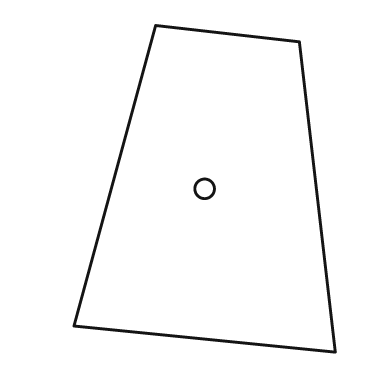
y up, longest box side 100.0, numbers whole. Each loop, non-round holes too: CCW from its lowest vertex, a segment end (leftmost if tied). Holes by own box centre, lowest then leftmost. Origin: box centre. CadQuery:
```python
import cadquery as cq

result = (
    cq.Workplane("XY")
    .moveTo(40.0, -50.0)
    .lineTo(29.0, 45.0)
    .lineTo(-15.0, 50.0)
    .lineTo(-40.0, -42.0)
    .close()
    .moveTo(0.0, 0.0)
    .circle(3.0)
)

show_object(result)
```